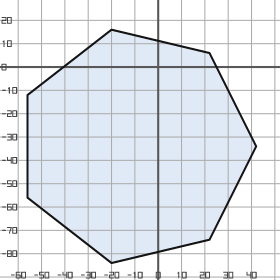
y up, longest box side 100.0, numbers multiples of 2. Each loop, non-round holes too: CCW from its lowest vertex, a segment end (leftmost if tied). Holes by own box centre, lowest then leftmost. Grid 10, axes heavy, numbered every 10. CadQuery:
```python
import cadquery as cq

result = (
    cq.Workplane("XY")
    .moveTo(-20.0, -84.0)
    .lineTo(22.0, -74.0)
    .lineTo(42.0, -34.0)
    .lineTo(22.0, 6.0)
    .lineTo(-20.0, 16.0)
    .lineTo(-56.0, -12.0)
    .lineTo(-56.0, -56.0)
    .close()
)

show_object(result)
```